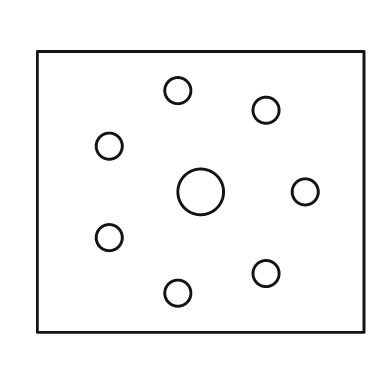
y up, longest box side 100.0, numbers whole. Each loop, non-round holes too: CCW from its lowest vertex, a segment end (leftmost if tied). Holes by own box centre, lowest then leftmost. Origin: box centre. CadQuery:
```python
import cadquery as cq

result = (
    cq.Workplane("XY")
    .moveTo(-50.0, -43.0)
    .lineTo(50.0, -43.0)
    .lineTo(50.0, 43.0)
    .lineTo(-50.0, 43.0)
    .close()
    .moveTo(-7.0, -31.0)
    .circle(4.0)
    .moveTo(20.0, -25.0)
    .circle(4.0)
    .moveTo(-28.0, -14.0)
    .circle(4.0)
    .moveTo(0.0, 0.0)
    .circle(7.0)
    .moveTo(32.0, 0.0)
    .circle(4.0)
    .moveTo(-28.0, 14.0)
    .circle(4.0)
    .moveTo(20.0, 25.0)
    .circle(4.0)
    .moveTo(-7.0, 31.0)
    .circle(4.0)
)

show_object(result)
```